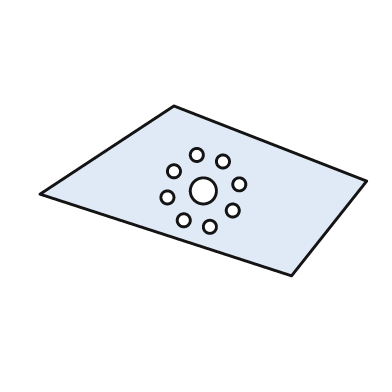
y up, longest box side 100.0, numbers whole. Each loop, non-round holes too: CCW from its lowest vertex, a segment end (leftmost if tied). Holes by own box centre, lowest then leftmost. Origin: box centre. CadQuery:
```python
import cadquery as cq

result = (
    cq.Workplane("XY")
    .moveTo(27.0, -26.0)
    .lineTo(50.0, 3.0)
    .lineTo(-9.0, 26.0)
    .lineTo(-50.0, -1.0)
    .close()
    .moveTo(2.0, -11.0)
    .circle(2.0)
    .moveTo(-6.0, -9.0)
    .circle(2.0)
    .moveTo(9.0, -6.0)
    .circle(2.0)
    .moveTo(-11.0, -2.0)
    .circle(2.0)
    .moveTo(0.0, 0.0)
    .circle(4.0)
    .moveTo(11.0, 2.0)
    .circle(2.0)
    .moveTo(-9.0, 6.0)
    .circle(2.0)
    .moveTo(6.0, 9.0)
    .circle(2.0)
    .moveTo(-2.0, 11.0)
    .circle(2.0)
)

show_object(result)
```